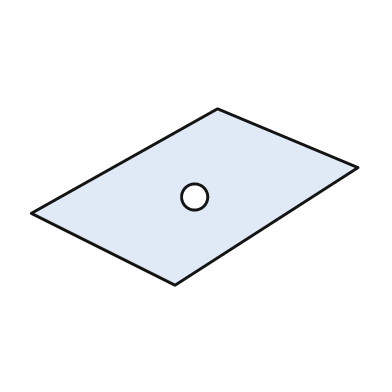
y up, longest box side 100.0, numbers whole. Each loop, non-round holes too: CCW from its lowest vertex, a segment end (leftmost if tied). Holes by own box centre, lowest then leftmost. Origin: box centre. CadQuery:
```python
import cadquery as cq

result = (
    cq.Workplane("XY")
    .moveTo(-6.0, -27.0)
    .lineTo(50.0, 9.0)
    .lineTo(7.0, 27.0)
    .lineTo(-50.0, -5.0)
    .close()
    .moveTo(0.0, 0.0)
    .circle(4.0)
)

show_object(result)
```